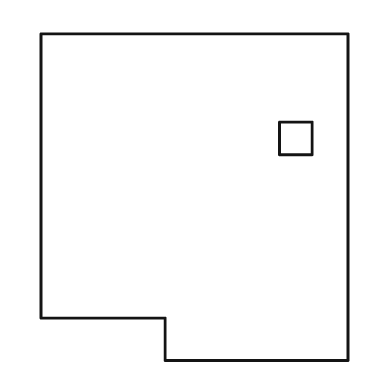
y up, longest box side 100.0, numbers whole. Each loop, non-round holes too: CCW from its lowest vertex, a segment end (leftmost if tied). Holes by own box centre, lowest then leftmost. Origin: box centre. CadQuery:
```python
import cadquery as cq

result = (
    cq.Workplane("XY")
    .moveTo(-9.0, -50.0)
    .lineTo(47.0, -50.0)
    .lineTo(47.0, 50.0)
    .lineTo(-47.0, 50.0)
    .lineTo(-47.0, -37.0)
    .lineTo(-9.0, -37.0)
    .close()
    .moveTo(26.0, 13.0)
    .lineTo(36.0, 13.0)
    .lineTo(36.0, 23.0)
    .lineTo(26.0, 23.0)
    .close()
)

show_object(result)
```